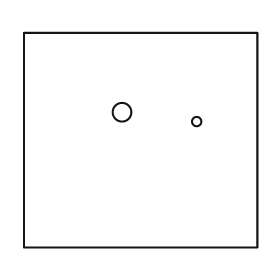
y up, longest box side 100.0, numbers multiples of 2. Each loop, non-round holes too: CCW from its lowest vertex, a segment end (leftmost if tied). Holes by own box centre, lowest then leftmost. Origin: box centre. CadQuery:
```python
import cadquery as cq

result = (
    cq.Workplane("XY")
    .moveTo(-50.0, -46.0)
    .lineTo(50.0, -46.0)
    .lineTo(50.0, 46.0)
    .lineTo(-50.0, 46.0)
    .close()
    .moveTo(24.0, 8.0)
    .circle(2.0)
    .moveTo(-8.0, 12.0)
    .circle(4.0)
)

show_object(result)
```